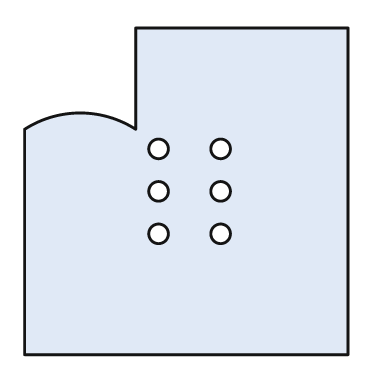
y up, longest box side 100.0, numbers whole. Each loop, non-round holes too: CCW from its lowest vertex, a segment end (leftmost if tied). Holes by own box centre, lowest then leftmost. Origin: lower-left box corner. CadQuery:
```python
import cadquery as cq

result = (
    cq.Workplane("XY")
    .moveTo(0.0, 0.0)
    .lineTo(99.0, 0.0)
    .lineTo(99.0, 100.0)
    .lineTo(34.0, 100.0)
    .lineTo(34.0, 69.0)
    .threePointArc((17.0, 74.0), (0.0, 69.0))
    .close()
    .moveTo(41.0, 37.0)
    .circle(3.0)
    .moveTo(60.0, 37.0)
    .circle(3.0)
    .moveTo(41.0, 50.0)
    .circle(3.0)
    .moveTo(60.0, 50.0)
    .circle(3.0)
    .moveTo(41.0, 63.0)
    .circle(3.0)
    .moveTo(60.0, 63.0)
    .circle(3.0)
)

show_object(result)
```